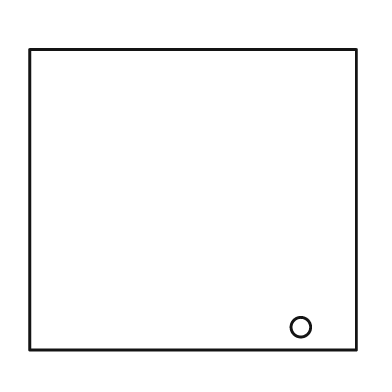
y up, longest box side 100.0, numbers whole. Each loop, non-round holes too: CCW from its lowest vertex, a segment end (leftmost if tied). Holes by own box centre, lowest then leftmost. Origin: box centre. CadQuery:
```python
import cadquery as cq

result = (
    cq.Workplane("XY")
    .moveTo(-50.0, -46.0)
    .lineTo(50.0, -46.0)
    .lineTo(50.0, 46.0)
    .lineTo(-50.0, 46.0)
    .close()
    .moveTo(33.0, -39.0)
    .circle(3.0)
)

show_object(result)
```